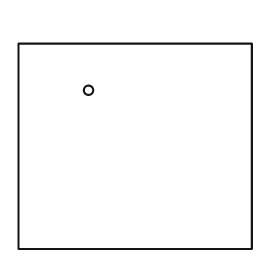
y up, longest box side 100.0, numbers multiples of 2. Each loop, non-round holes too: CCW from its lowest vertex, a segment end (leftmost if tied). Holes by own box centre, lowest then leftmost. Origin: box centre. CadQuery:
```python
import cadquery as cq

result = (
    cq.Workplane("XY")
    .moveTo(-50.0, -44.0)
    .lineTo(50.0, -44.0)
    .lineTo(50.0, 44.0)
    .lineTo(-50.0, 44.0)
    .close()
    .moveTo(-20.0, 24.0)
    .circle(2.0)
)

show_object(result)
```